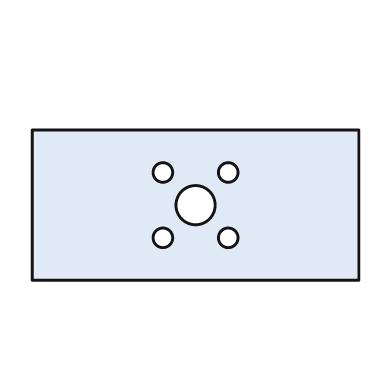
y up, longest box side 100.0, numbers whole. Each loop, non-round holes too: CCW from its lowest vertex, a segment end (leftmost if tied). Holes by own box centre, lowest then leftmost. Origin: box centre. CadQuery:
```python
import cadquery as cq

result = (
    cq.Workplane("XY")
    .moveTo(-50.0, -23.0)
    .lineTo(50.0, -23.0)
    .lineTo(50.0, 23.0)
    .lineTo(-50.0, 23.0)
    .close()
    .moveTo(-10.0, -10.0)
    .circle(3.0)
    .moveTo(10.0, -10.0)
    .circle(3.0)
    .moveTo(0.0, 0.0)
    .circle(6.0)
    .moveTo(-10.0, 10.0)
    .circle(3.0)
    .moveTo(10.0, 10.0)
    .circle(3.0)
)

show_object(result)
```